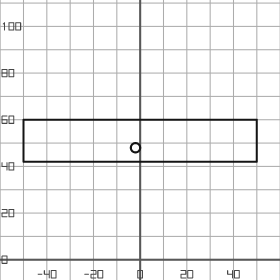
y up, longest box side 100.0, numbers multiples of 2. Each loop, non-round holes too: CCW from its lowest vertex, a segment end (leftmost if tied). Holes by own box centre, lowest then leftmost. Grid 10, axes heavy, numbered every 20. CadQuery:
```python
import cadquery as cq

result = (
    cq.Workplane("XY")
    .moveTo(-50.0, 42.0)
    .lineTo(50.0, 42.0)
    .lineTo(50.0, 60.0)
    .lineTo(-50.0, 60.0)
    .close()
    .moveTo(-2.0, 48.0)
    .circle(2.0)
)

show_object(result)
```